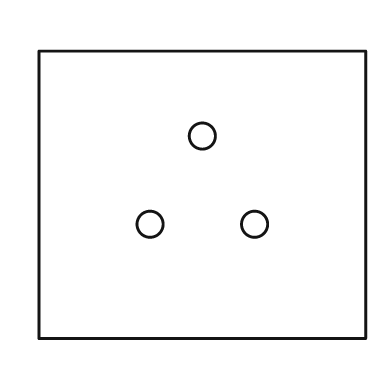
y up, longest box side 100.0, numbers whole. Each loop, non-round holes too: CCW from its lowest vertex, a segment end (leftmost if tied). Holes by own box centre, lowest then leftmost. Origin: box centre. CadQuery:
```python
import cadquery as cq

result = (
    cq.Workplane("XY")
    .moveTo(-50.0, -44.0)
    .lineTo(50.0, -44.0)
    .lineTo(50.0, 44.0)
    .lineTo(-50.0, 44.0)
    .close()
    .moveTo(-16.0, -9.0)
    .circle(4.0)
    .moveTo(16.0, -9.0)
    .circle(4.0)
    .moveTo(0.0, 18.0)
    .circle(4.0)
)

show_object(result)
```